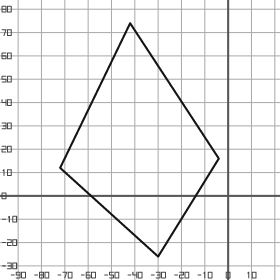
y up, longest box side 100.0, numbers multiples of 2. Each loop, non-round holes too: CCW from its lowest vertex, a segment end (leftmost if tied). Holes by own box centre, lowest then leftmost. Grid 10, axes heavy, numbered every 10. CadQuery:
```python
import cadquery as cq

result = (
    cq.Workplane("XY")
    .moveTo(-30.0, -26.0)
    .lineTo(-4.0, 16.0)
    .lineTo(-42.0, 74.0)
    .lineTo(-72.0, 12.0)
    .close()
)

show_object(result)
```